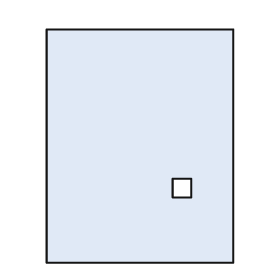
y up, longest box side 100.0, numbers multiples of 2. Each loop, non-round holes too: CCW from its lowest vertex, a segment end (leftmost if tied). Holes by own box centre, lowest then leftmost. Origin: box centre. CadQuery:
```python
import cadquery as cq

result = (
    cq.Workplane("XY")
    .moveTo(-40.0, -50.0)
    .lineTo(40.0, -50.0)
    .lineTo(40.0, 50.0)
    .lineTo(-40.0, 50.0)
    .close()
    .moveTo(14.0, -22.0)
    .lineTo(22.0, -22.0)
    .lineTo(22.0, -14.0)
    .lineTo(14.0, -14.0)
    .close()
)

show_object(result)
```